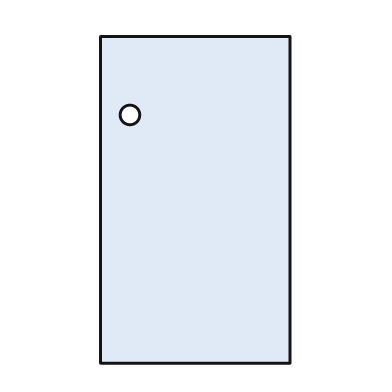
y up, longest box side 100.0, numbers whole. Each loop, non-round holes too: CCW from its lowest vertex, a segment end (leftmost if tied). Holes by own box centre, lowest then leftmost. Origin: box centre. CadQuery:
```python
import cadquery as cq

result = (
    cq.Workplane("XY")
    .moveTo(-29.0, -50.0)
    .lineTo(29.0, -50.0)
    .lineTo(29.0, 50.0)
    .lineTo(-29.0, 50.0)
    .close()
    .moveTo(-20.0, 26.0)
    .circle(3.0)
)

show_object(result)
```